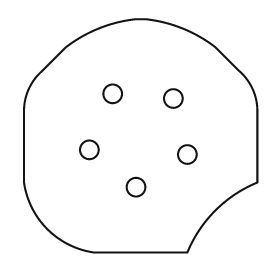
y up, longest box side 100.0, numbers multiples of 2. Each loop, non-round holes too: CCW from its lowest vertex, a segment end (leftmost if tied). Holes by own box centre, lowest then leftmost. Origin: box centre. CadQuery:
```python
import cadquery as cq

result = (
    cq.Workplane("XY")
    .moveTo(-20.0, -50.0)
    .lineTo(20.0, -50.0)
    .threePointArc((32.0, -32.0), (50.0, -20.0))
    .lineTo(50.0, 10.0)
    .threePointArc((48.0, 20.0), (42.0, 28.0))
    .lineTo(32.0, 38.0)
    .threePointArc((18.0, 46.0), (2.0, 50.0))
    .lineTo(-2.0, 50.0)
    .threePointArc((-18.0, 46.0), (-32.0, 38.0))
    .lineTo(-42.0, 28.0)
    .threePointArc((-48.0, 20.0), (-50.0, 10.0))
    .lineTo(-50.0, -20.0)
    .threePointArc((-40.0, -40.0), (-20.0, -50.0))
    .close()
    .moveTo(-2.0, -22.0)
    .circle(4.0)
    .moveTo(20.0, -8.0)
    .circle(4.0)
    .moveTo(-22.0, -6.0)
    .circle(4.0)
    .moveTo(14.0, 16.0)
    .circle(4.0)
    .moveTo(-12.0, 18.0)
    .circle(4.0)
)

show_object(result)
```